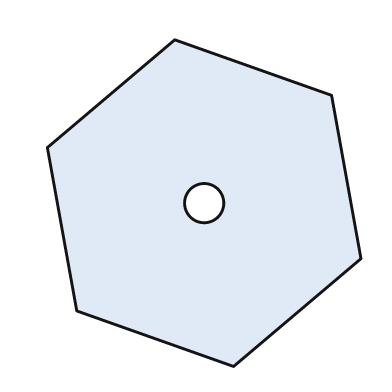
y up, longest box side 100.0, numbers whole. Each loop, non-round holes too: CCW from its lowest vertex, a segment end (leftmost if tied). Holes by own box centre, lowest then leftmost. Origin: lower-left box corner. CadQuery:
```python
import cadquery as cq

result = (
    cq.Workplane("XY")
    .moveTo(57.0, 0.0)
    .lineTo(96.0, 33.0)
    .lineTo(87.0, 83.0)
    .lineTo(39.0, 100.0)
    .lineTo(0.0, 67.0)
    .lineTo(9.0, 17.0)
    .close()
    .moveTo(48.0, 50.0)
    .circle(6.0)
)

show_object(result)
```